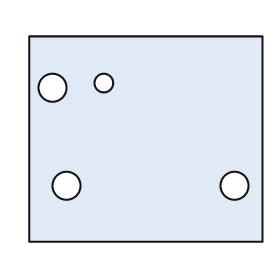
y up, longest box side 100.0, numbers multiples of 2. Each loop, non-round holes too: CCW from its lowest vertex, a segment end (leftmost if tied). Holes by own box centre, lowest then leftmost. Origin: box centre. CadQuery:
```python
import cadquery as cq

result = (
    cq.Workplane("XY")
    .moveTo(-50.0, -44.0)
    .lineTo(50.0, -44.0)
    .lineTo(50.0, 44.0)
    .lineTo(-50.0, 44.0)
    .close()
    .moveTo(-34.0, -20.0)
    .circle(6.0)
    .moveTo(38.0, -20.0)
    .circle(6.0)
    .moveTo(-40.0, 22.0)
    .circle(6.0)
    .moveTo(-18.0, 24.0)
    .circle(4.0)
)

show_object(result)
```